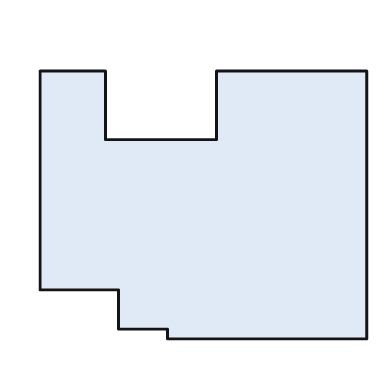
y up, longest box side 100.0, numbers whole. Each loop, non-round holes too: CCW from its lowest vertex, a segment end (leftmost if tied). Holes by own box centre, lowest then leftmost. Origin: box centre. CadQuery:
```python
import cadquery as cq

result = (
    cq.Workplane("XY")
    .moveTo(-11.0, -41.0)
    .lineTo(50.0, -41.0)
    .lineTo(50.0, 41.0)
    .lineTo(4.0, 41.0)
    .lineTo(4.0, 20.0)
    .lineTo(-30.0, 20.0)
    .lineTo(-30.0, 41.0)
    .lineTo(-50.0, 41.0)
    .lineTo(-50.0, -26.0)
    .lineTo(-26.0, -26.0)
    .lineTo(-26.0, -38.0)
    .lineTo(-11.0, -38.0)
    .close()
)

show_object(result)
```